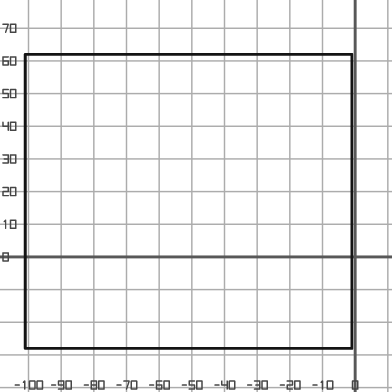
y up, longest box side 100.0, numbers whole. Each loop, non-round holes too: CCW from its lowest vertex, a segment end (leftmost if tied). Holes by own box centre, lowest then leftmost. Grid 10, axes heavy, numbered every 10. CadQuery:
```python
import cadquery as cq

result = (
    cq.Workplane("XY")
    .moveTo(-101.0, -28.0)
    .lineTo(-1.0, -28.0)
    .lineTo(-1.0, 62.0)
    .lineTo(-101.0, 62.0)
    .close()
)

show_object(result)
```